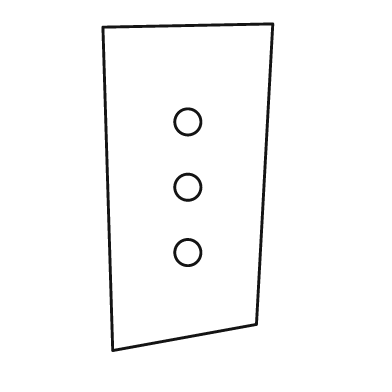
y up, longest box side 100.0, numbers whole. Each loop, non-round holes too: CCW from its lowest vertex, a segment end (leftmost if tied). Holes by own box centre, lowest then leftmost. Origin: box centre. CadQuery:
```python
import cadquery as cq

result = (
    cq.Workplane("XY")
    .moveTo(-23.0, -50.0)
    .lineTo(21.0, -42.0)
    .lineTo(26.0, 50.0)
    .lineTo(-26.0, 49.0)
    .close()
    .moveTo(0.0, -20.0)
    .circle(4.0)
    .moveTo(0.0, 0.0)
    .circle(4.0)
    .moveTo(0.0, 20.0)
    .circle(4.0)
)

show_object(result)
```